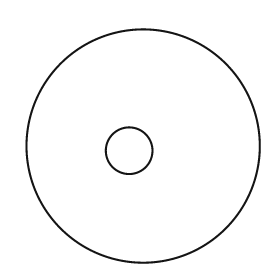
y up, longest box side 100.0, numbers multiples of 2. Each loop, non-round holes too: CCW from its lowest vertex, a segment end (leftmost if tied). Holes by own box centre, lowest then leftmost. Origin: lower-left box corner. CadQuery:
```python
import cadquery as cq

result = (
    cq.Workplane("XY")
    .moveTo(50.0, 50.0)
    .circle(50.0)
    .moveTo(44.0, 48.0)
    .circle(10.0)
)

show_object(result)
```